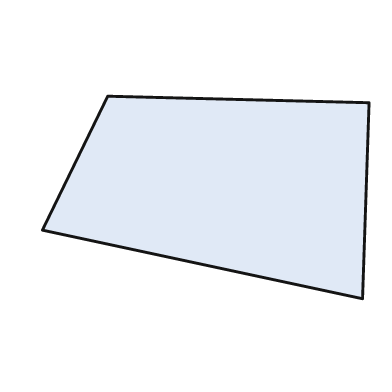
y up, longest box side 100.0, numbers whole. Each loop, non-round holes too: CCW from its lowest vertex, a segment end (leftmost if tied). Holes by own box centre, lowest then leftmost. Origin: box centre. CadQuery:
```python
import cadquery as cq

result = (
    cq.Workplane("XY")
    .moveTo(48.0, -31.0)
    .lineTo(50.0, 29.0)
    .lineTo(-30.0, 31.0)
    .lineTo(-50.0, -10.0)
    .close()
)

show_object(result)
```